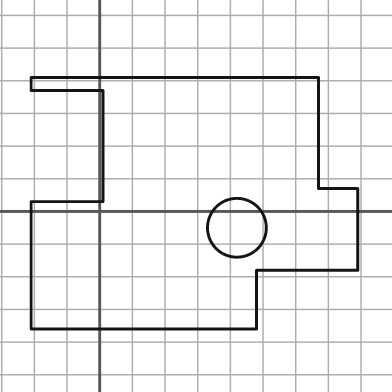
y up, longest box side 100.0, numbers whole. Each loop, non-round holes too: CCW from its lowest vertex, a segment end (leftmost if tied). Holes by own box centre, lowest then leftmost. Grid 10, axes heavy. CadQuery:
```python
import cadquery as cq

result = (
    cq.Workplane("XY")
    .moveTo(-21.0, -36.0)
    .lineTo(48.0, -36.0)
    .lineTo(48.0, -18.0)
    .lineTo(79.0, -18.0)
    .lineTo(79.0, 7.0)
    .lineTo(67.0, 7.0)
    .lineTo(67.0, 41.0)
    .lineTo(-21.0, 41.0)
    .lineTo(-21.0, 37.0)
    .lineTo(1.0, 37.0)
    .lineTo(1.0, 3.0)
    .lineTo(-21.0, 3.0)
    .close()
    .moveTo(42.0, -5.0)
    .circle(9.0)
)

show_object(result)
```